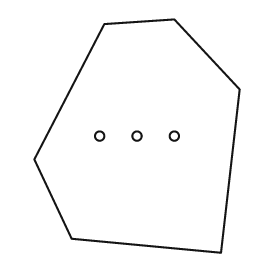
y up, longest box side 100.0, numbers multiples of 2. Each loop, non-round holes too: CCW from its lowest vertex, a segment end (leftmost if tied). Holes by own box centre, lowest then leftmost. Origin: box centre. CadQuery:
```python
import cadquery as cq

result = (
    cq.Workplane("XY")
    .moveTo(36.0, -50.0)
    .lineTo(44.0, 20.0)
    .lineTo(16.0, 50.0)
    .lineTo(-14.0, 48.0)
    .lineTo(-44.0, -10.0)
    .lineTo(-28.0, -44.0)
    .close()
    .moveTo(-16.0, 0.0)
    .circle(2.0)
    .moveTo(0.0, 0.0)
    .circle(2.0)
    .moveTo(16.0, 0.0)
    .circle(2.0)
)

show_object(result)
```